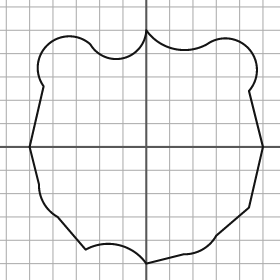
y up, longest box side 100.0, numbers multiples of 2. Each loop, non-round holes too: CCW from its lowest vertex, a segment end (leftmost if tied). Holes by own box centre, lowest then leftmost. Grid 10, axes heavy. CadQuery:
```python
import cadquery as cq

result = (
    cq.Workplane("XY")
    .moveTo(0.0, -50.0)
    .lineTo(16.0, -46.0)
    .threePointArc((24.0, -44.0), (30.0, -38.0))
    .lineTo(44.0, -26.0)
    .lineTo(50.0, 0.0)
    .lineTo(44.0, 24.0)
    .threePointArc((44.0, 42.0), (26.0, 44.0))
    .threePointArc((12.0, 42.0), (0.0, 50.0))
    .threePointArc((-10.0, 38.0), (-24.0, 44.0))
    .threePointArc((-42.0, 44.0), (-44.0, 26.0))
    .lineTo(-50.0, 0.0)
    .lineTo(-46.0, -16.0)
    .threePointArc((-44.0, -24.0), (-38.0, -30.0))
    .lineTo(-26.0, -44.0)
    .threePointArc((-12.0, -42.0), (0.0, -50.0))
    .close()
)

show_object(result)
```